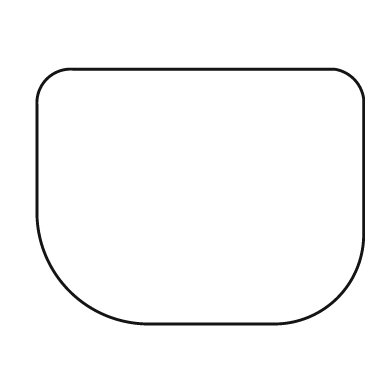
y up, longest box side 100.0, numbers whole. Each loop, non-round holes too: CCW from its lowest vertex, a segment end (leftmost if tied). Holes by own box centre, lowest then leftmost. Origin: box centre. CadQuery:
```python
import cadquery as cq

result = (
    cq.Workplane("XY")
    .moveTo(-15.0, -39.0)
    .lineTo(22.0, -39.0)
    .threePointArc((42.0, -31.0), (50.0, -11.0))
    .lineTo(50.0, 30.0)
    .threePointArc((47.0, 36.0), (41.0, 39.0))
    .lineTo(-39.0, 39.0)
    .threePointArc((-47.0, 36.0), (-50.0, 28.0))
    .lineTo(-50.0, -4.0)
    .threePointArc((-40.0, -29.0), (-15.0, -39.0))
    .close()
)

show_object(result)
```